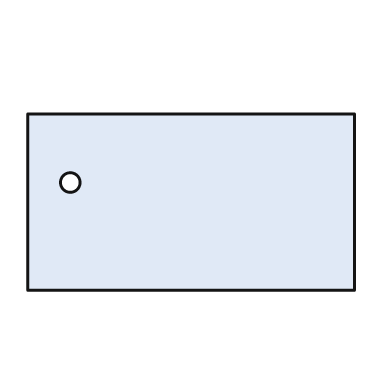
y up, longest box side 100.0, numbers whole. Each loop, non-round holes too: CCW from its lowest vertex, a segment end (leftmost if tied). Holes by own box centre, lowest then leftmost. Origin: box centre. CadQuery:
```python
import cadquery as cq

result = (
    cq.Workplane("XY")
    .moveTo(-50.0, -27.0)
    .lineTo(50.0, -27.0)
    .lineTo(50.0, 27.0)
    .lineTo(-50.0, 27.0)
    .close()
    .moveTo(-37.0, 6.0)
    .circle(3.0)
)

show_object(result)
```